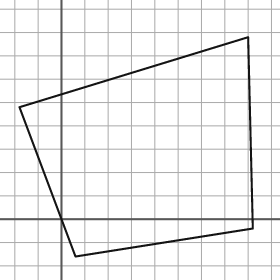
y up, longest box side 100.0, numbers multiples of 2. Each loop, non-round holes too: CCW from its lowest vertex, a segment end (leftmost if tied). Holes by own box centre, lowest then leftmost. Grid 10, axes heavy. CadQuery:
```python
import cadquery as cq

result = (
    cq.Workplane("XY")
    .moveTo(6.0, -16.0)
    .lineTo(82.0, -4.0)
    .lineTo(80.0, 78.0)
    .lineTo(-18.0, 48.0)
    .close()
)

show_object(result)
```